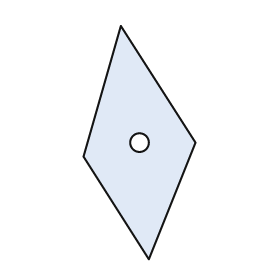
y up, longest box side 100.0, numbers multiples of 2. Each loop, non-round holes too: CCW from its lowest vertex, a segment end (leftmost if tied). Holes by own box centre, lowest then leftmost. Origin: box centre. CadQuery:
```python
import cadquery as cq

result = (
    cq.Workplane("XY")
    .moveTo(4.0, -50.0)
    .lineTo(24.0, 0.0)
    .lineTo(-8.0, 50.0)
    .lineTo(-24.0, -6.0)
    .close()
    .moveTo(0.0, 0.0)
    .circle(4.0)
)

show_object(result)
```